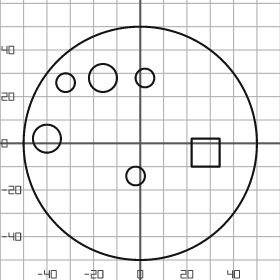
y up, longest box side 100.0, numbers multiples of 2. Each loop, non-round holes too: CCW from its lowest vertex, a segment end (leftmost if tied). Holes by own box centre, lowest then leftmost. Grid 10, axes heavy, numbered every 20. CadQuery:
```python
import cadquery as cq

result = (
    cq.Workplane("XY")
    .moveTo(0.0, 0.0)
    .circle(50.0)
    .moveTo(-2.0, -14.0)
    .circle(4.0)
    .moveTo(22.0, -10.0)
    .lineTo(34.0, -10.0)
    .lineTo(34.0, 2.0)
    .lineTo(22.0, 2.0)
    .close()
    .moveTo(-40.0, 2.0)
    .circle(6.0)
    .moveTo(-32.0, 26.0)
    .circle(4.0)
    .moveTo(-16.0, 28.0)
    .circle(6.0)
    .moveTo(2.0, 28.0)
    .circle(4.0)
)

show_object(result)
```